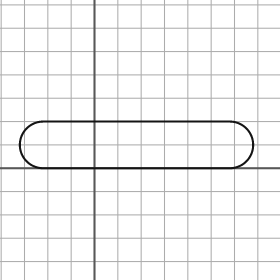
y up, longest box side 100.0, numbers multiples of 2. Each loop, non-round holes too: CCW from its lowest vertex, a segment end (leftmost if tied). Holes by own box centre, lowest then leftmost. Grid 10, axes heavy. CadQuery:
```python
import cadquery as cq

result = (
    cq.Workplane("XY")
    .moveTo(-22.0, 0.0)
    .lineTo(58.0, 0.0)
    .threePointArc((68.0, 10.0), (58.0, 20.0))
    .lineTo(-22.0, 20.0)
    .threePointArc((-32.0, 10.0), (-22.0, 0.0))
    .close()
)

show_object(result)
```